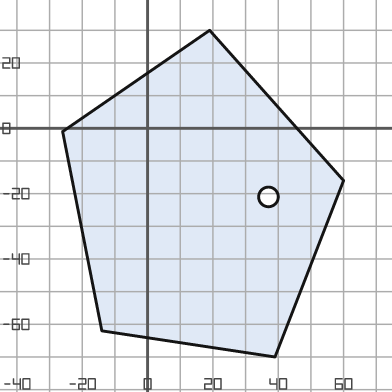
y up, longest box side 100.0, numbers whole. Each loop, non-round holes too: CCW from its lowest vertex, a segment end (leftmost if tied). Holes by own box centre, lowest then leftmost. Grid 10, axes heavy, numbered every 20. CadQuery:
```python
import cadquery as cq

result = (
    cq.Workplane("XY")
    .moveTo(39.0, -70.0)
    .lineTo(60.0, -16.0)
    .lineTo(19.0, 30.0)
    .lineTo(-26.0, -1.0)
    .lineTo(-14.0, -62.0)
    .close()
    .moveTo(37.0, -21.0)
    .circle(3.0)
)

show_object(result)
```